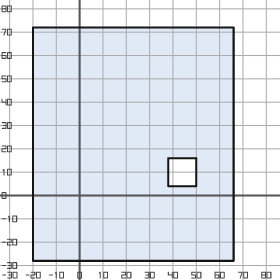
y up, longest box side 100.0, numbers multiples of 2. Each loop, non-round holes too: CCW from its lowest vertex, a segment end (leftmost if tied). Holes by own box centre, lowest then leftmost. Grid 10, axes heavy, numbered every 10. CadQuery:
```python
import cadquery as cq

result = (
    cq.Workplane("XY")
    .moveTo(-20.0, -28.0)
    .lineTo(66.0, -28.0)
    .lineTo(66.0, 72.0)
    .lineTo(-20.0, 72.0)
    .close()
    .moveTo(38.0, 4.0)
    .lineTo(50.0, 4.0)
    .lineTo(50.0, 16.0)
    .lineTo(38.0, 16.0)
    .close()
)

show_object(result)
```